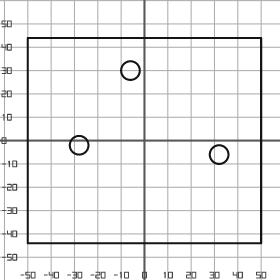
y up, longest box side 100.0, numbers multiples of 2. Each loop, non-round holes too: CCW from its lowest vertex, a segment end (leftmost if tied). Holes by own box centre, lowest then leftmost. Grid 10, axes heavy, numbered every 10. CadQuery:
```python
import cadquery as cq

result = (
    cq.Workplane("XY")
    .moveTo(-50.0, -44.0)
    .lineTo(50.0, -44.0)
    .lineTo(50.0, 44.0)
    .lineTo(-50.0, 44.0)
    .close()
    .moveTo(32.0, -6.0)
    .circle(4.0)
    .moveTo(-28.0, -2.0)
    .circle(4.0)
    .moveTo(-6.0, 30.0)
    .circle(4.0)
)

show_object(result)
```